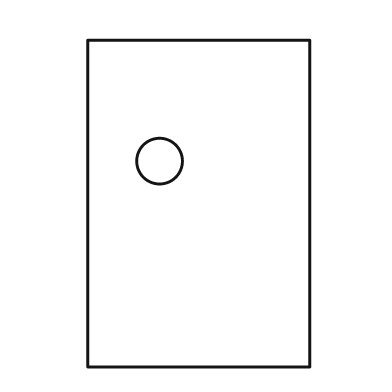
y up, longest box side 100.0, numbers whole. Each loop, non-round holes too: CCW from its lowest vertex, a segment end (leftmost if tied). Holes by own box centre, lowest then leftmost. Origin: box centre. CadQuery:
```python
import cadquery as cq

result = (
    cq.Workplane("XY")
    .moveTo(-34.0, -50.0)
    .lineTo(34.0, -50.0)
    .lineTo(34.0, 50.0)
    .lineTo(-34.0, 50.0)
    .close()
    .moveTo(-12.0, 13.0)
    .circle(7.0)
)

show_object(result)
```